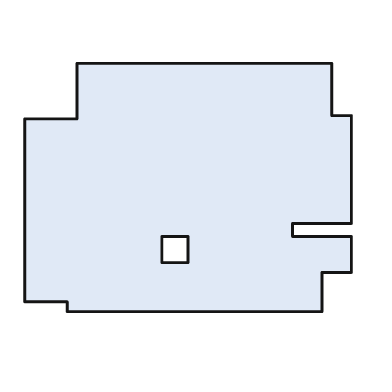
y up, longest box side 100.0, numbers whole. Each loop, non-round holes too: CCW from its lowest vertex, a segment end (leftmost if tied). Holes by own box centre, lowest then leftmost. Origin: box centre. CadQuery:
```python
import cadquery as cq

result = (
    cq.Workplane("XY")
    .moveTo(-37.0, -38.0)
    .lineTo(41.0, -38.0)
    .lineTo(41.0, -26.0)
    .lineTo(50.0, -26.0)
    .lineTo(50.0, -15.0)
    .lineTo(32.0, -15.0)
    .lineTo(32.0, -11.0)
    .lineTo(50.0, -11.0)
    .lineTo(50.0, 22.0)
    .lineTo(44.0, 22.0)
    .lineTo(44.0, 38.0)
    .lineTo(-34.0, 38.0)
    .lineTo(-34.0, 21.0)
    .lineTo(-50.0, 21.0)
    .lineTo(-50.0, -35.0)
    .lineTo(-37.0, -35.0)
    .close()
    .moveTo(-8.0, -23.0)
    .lineTo(0.0, -23.0)
    .lineTo(0.0, -15.0)
    .lineTo(-8.0, -15.0)
    .close()
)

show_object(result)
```